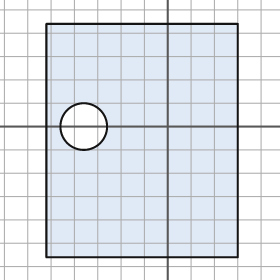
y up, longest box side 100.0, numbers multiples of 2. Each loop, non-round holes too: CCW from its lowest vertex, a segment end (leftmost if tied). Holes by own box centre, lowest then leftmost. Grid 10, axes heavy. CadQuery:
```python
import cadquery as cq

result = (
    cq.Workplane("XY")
    .moveTo(-52.0, -56.0)
    .lineTo(30.0, -56.0)
    .lineTo(30.0, 44.0)
    .lineTo(-52.0, 44.0)
    .close()
    .moveTo(-36.0, 0.0)
    .circle(10.0)
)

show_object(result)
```